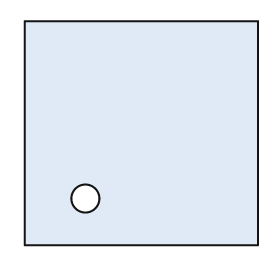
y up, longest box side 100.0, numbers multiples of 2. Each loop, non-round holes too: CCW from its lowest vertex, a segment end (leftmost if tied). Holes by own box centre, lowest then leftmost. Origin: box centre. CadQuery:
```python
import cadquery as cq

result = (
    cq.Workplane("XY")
    .moveTo(-50.0, -48.0)
    .lineTo(50.0, -48.0)
    .lineTo(50.0, 48.0)
    .lineTo(-50.0, 48.0)
    .close()
    .moveTo(-24.0, -28.0)
    .circle(6.0)
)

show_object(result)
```